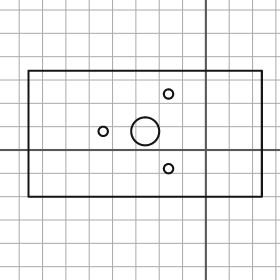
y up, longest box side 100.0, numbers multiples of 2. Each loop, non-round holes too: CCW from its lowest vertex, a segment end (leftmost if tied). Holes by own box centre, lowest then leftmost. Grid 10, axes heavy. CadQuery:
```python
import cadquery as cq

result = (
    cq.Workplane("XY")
    .moveTo(-76.0, -20.0)
    .lineTo(24.0, -20.0)
    .lineTo(24.0, 34.0)
    .lineTo(-76.0, 34.0)
    .close()
    .moveTo(-16.0, -8.0)
    .circle(2.0)
    .moveTo(-44.0, 8.0)
    .circle(2.0)
    .moveTo(-26.0, 8.0)
    .circle(6.0)
    .moveTo(-16.0, 24.0)
    .circle(2.0)
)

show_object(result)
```